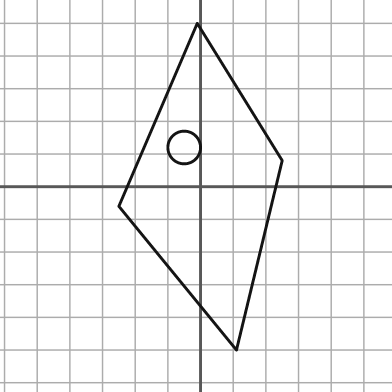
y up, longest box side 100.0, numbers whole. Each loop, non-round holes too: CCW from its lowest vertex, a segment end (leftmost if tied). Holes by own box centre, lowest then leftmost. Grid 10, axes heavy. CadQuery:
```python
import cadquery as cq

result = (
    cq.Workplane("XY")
    .moveTo(11.0, -50.0)
    .lineTo(25.0, 8.0)
    .lineTo(-1.0, 50.0)
    .lineTo(-25.0, -6.0)
    .close()
    .moveTo(-5.0, 12.0)
    .circle(5.0)
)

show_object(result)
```